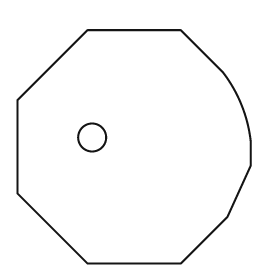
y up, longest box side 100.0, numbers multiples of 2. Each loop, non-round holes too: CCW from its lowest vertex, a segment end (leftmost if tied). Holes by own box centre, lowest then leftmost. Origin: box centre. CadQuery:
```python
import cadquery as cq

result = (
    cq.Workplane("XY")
    .moveTo(-20.0, -50.0)
    .lineTo(20.0, -50.0)
    .lineTo(40.0, -30.0)
    .lineTo(50.0, -8.0)
    .lineTo(50.0, 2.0)
    .threePointArc((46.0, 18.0), (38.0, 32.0))
    .lineTo(20.0, 50.0)
    .lineTo(-20.0, 50.0)
    .lineTo(-50.0, 20.0)
    .lineTo(-50.0, -20.0)
    .close()
    .moveTo(-18.0, 4.0)
    .circle(6.0)
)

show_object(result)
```